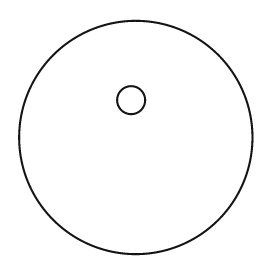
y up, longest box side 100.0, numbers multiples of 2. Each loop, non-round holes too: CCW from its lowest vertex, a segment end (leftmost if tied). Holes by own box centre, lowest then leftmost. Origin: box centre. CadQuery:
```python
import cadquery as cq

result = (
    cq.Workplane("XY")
    .moveTo(0.0, 0.0)
    .circle(50.0)
    .moveTo(-2.0, 16.0)
    .circle(6.0)
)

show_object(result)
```